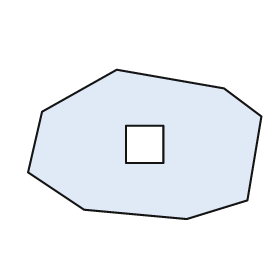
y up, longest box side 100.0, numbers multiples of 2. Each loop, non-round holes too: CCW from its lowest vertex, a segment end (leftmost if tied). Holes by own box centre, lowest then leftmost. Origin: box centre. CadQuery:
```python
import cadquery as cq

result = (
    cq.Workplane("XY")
    .moveTo(18.0, -32.0)
    .lineTo(44.0, -24.0)
    .lineTo(50.0, 12.0)
    .lineTo(34.0, 24.0)
    .lineTo(-12.0, 32.0)
    .lineTo(-44.0, 14.0)
    .lineTo(-50.0, -12.0)
    .lineTo(-26.0, -28.0)
    .close()
    .moveTo(-8.0, -8.0)
    .lineTo(8.0, -8.0)
    .lineTo(8.0, 8.0)
    .lineTo(-8.0, 8.0)
    .close()
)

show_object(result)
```